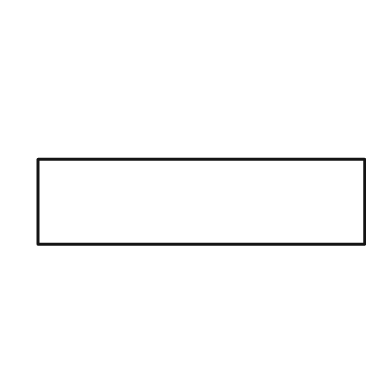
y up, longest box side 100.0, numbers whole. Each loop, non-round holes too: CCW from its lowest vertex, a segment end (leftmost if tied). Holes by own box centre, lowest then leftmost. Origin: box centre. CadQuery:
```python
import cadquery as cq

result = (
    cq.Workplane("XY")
    .moveTo(-50.0, -13.0)
    .lineTo(50.0, -13.0)
    .lineTo(50.0, 13.0)
    .lineTo(-50.0, 13.0)
    .close()
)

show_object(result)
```